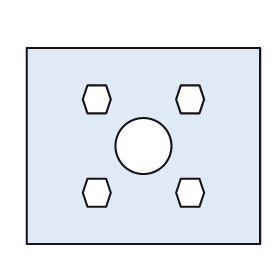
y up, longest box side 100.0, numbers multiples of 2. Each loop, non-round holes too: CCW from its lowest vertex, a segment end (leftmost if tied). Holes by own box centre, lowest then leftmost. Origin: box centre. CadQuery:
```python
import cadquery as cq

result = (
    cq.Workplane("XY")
    .moveTo(-50.0, -42.0)
    .lineTo(50.0, -42.0)
    .lineTo(50.0, 42.0)
    .lineTo(-50.0, 42.0)
    .close()
    .moveTo(-24.0, -26.0)
    .lineTo(-16.0, -26.0)
    .lineTo(-14.0, -20.0)
    .lineTo(-16.0, -14.0)
    .lineTo(-24.0, -14.0)
    .lineTo(-26.0, -20.0)
    .close()
    .moveTo(16.0, -26.0)
    .lineTo(24.0, -26.0)
    .lineTo(26.0, -20.0)
    .lineTo(24.0, -14.0)
    .lineTo(16.0, -14.0)
    .lineTo(14.0, -20.0)
    .close()
    .moveTo(0.0, 0.0)
    .circle(12.0)
    .moveTo(-24.0, 14.0)
    .lineTo(-16.0, 14.0)
    .lineTo(-14.0, 20.0)
    .lineTo(-16.0, 26.0)
    .lineTo(-24.0, 26.0)
    .lineTo(-26.0, 20.0)
    .close()
    .moveTo(16.0, 14.0)
    .lineTo(24.0, 14.0)
    .lineTo(26.0, 20.0)
    .lineTo(24.0, 26.0)
    .lineTo(16.0, 26.0)
    .lineTo(14.0, 20.0)
    .close()
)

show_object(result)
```